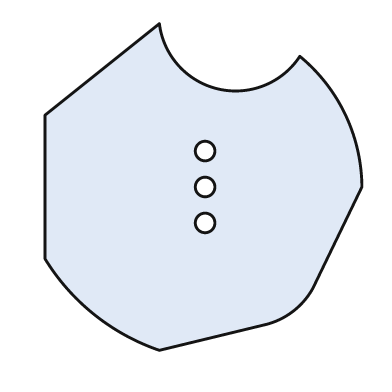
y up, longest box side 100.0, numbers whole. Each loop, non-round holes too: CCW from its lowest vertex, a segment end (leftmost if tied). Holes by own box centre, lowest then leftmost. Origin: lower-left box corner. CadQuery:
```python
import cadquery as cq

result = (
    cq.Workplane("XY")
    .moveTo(35.0, 0.0)
    .lineTo(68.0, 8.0)
    .threePointArc((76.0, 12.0), (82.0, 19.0))
    .lineTo(97.0, 50.0)
    .threePointArc((92.0, 72.0), (78.0, 90.0))
    .threePointArc((53.0, 80.0), (35.0, 100.0))
    .lineTo(0.0, 72.0)
    .lineTo(0.0, 28.0)
    .threePointArc((15.0, 11.0), (35.0, 0.0))
    .close()
    .moveTo(49.0, 39.0)
    .circle(3.0)
    .moveTo(49.0, 50.0)
    .circle(3.0)
    .moveTo(49.0, 61.0)
    .circle(3.0)
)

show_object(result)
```